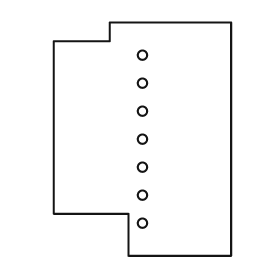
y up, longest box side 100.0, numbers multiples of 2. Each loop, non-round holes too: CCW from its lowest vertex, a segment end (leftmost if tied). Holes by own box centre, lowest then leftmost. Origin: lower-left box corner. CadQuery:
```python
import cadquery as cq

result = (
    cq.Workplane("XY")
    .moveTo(32.0, 0.0)
    .lineTo(76.0, 0.0)
    .lineTo(76.0, 100.0)
    .lineTo(24.0, 100.0)
    .lineTo(24.0, 92.0)
    .lineTo(0.0, 92.0)
    .lineTo(0.0, 18.0)
    .lineTo(32.0, 18.0)
    .close()
    .moveTo(38.0, 14.0)
    .circle(2.0)
    .moveTo(38.0, 26.0)
    .circle(2.0)
    .moveTo(38.0, 38.0)
    .circle(2.0)
    .moveTo(38.0, 50.0)
    .circle(2.0)
    .moveTo(38.0, 62.0)
    .circle(2.0)
    .moveTo(38.0, 74.0)
    .circle(2.0)
    .moveTo(38.0, 86.0)
    .circle(2.0)
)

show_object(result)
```